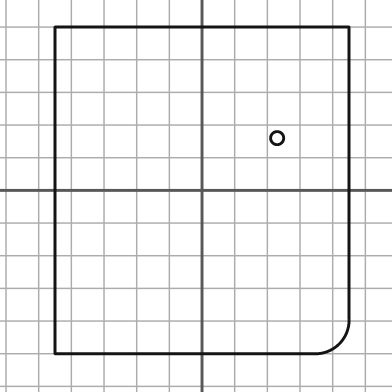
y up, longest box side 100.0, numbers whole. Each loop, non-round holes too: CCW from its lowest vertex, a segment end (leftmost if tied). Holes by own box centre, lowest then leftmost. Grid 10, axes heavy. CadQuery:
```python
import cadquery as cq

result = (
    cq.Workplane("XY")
    .moveTo(-45.0, -50.0)
    .lineTo(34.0, -50.0)
    .threePointArc((42.0, -47.0), (45.0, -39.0))
    .lineTo(45.0, 50.0)
    .lineTo(-45.0, 50.0)
    .close()
    .moveTo(23.0, 16.0)
    .circle(2.0)
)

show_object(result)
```